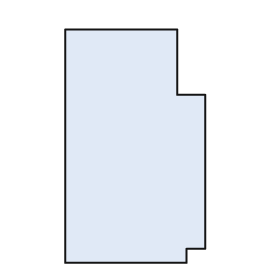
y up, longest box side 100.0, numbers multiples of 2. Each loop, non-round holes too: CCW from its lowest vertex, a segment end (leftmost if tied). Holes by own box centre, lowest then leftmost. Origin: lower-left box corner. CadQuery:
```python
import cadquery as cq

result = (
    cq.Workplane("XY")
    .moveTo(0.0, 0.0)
    .lineTo(52.0, 0.0)
    .lineTo(52.0, 6.0)
    .lineTo(60.0, 6.0)
    .lineTo(60.0, 72.0)
    .lineTo(48.0, 72.0)
    .lineTo(48.0, 100.0)
    .lineTo(0.0, 100.0)
    .close()
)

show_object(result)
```